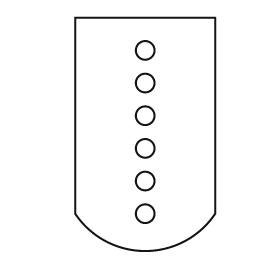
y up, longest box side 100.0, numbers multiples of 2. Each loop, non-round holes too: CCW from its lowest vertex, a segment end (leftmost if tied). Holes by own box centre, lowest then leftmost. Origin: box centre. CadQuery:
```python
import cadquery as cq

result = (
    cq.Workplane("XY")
    .moveTo(-30.0, -34.0)
    .threePointArc((0.0, -50.0), (30.0, -34.0))
    .lineTo(30.0, 50.0)
    .lineTo(-30.0, 50.0)
    .close()
    .moveTo(0.0, -34.0)
    .circle(4.0)
    .moveTo(0.0, -20.0)
    .circle(4.0)
    .moveTo(0.0, -6.0)
    .circle(4.0)
    .moveTo(0.0, 8.0)
    .circle(4.0)
    .moveTo(0.0, 22.0)
    .circle(4.0)
    .moveTo(0.0, 36.0)
    .circle(4.0)
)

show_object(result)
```